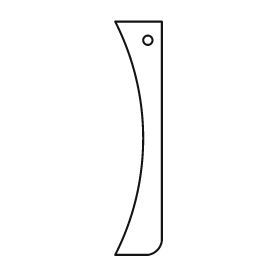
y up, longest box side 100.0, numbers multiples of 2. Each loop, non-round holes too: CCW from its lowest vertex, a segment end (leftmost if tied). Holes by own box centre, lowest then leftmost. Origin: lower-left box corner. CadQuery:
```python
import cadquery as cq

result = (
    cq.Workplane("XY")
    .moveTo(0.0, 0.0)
    .lineTo(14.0, 0.0)
    .threePointArc((18.0, 2.0), (20.0, 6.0))
    .lineTo(20.0, 100.0)
    .lineTo(0.0, 100.0)
    .threePointArc((12.0, 50.0), (0.0, 0.0))
    .close()
    .moveTo(14.0, 92.0)
    .circle(2.0)
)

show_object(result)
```